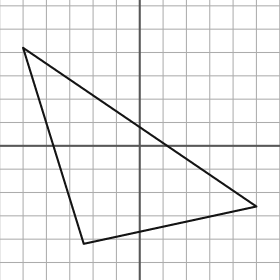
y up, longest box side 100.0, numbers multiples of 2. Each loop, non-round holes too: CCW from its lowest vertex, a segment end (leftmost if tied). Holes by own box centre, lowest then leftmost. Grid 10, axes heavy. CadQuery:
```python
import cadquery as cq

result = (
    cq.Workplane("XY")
    .moveTo(-24.0, -42.0)
    .lineTo(50.0, -26.0)
    .lineTo(-50.0, 42.0)
    .close()
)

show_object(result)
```